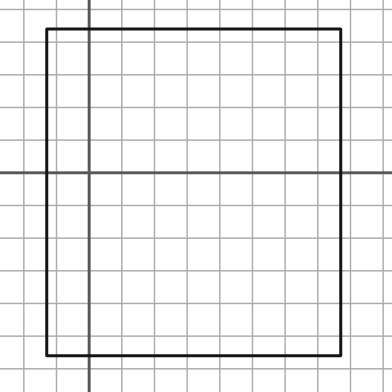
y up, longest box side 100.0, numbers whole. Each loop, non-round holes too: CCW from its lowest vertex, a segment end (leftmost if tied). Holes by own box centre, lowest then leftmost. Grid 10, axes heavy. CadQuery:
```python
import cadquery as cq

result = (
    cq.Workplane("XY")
    .moveTo(-13.0, -56.0)
    .lineTo(77.0, -56.0)
    .lineTo(77.0, 44.0)
    .lineTo(-13.0, 44.0)
    .close()
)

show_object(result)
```